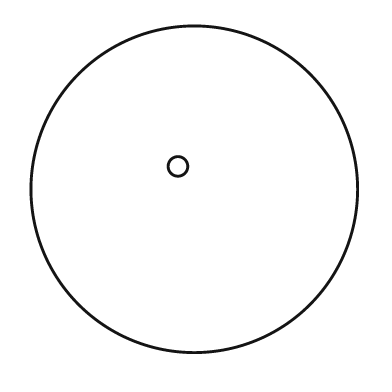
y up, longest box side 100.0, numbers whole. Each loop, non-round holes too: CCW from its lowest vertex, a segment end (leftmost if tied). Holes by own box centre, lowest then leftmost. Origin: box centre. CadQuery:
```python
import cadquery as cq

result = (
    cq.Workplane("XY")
    .moveTo(0.0, 0.0)
    .circle(50.0)
    .moveTo(-5.0, 7.0)
    .circle(3.0)
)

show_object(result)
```